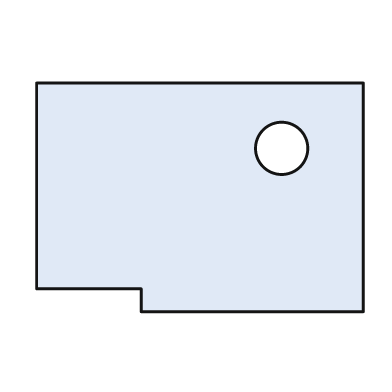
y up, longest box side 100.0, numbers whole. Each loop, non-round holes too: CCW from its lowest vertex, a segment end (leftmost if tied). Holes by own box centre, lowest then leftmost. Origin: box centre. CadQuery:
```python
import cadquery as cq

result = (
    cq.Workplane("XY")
    .moveTo(-18.0, -35.0)
    .lineTo(50.0, -35.0)
    .lineTo(50.0, 35.0)
    .lineTo(-50.0, 35.0)
    .lineTo(-50.0, -28.0)
    .lineTo(-18.0, -28.0)
    .close()
    .moveTo(25.0, 15.0)
    .circle(8.0)
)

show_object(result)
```